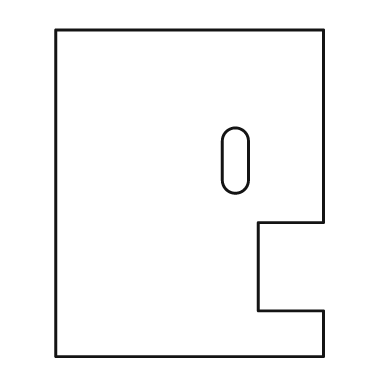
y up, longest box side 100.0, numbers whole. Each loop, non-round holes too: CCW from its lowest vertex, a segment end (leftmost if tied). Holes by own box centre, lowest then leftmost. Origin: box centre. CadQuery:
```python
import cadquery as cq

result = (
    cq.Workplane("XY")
    .moveTo(-41.0, -50.0)
    .lineTo(41.0, -50.0)
    .lineTo(41.0, -36.0)
    .lineTo(21.0, -36.0)
    .lineTo(21.0, -9.0)
    .lineTo(41.0, -9.0)
    .lineTo(41.0, 50.0)
    .lineTo(-41.0, 50.0)
    .close()
    .moveTo(10.0, 4.0)
    .threePointArc((14.0, 0.0), (18.0, 4.0))
    .lineTo(18.0, 16.0)
    .threePointArc((14.0, 20.0), (10.0, 16.0))
    .close()
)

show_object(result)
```